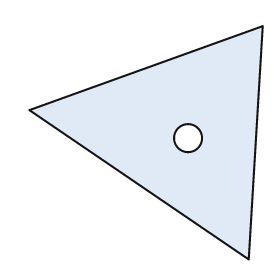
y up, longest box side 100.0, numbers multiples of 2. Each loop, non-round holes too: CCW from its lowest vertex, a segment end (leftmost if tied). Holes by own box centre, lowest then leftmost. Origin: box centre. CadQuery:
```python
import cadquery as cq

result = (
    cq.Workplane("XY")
    .moveTo(44.0, -50.0)
    .lineTo(50.0, 50.0)
    .lineTo(-50.0, 14.0)
    .close()
    .moveTo(18.0, 2.0)
    .circle(6.0)
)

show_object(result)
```